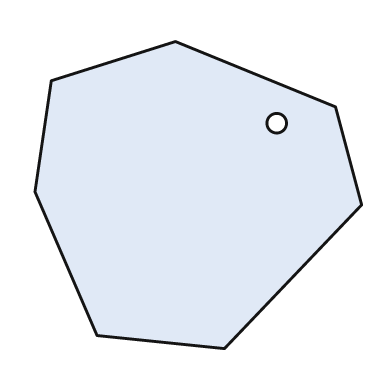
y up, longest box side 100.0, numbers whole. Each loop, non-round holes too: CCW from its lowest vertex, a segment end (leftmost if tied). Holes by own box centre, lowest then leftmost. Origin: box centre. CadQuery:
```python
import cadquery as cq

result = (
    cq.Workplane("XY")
    .moveTo(8.0, -47.0)
    .lineTo(50.0, -3.0)
    .lineTo(42.0, 27.0)
    .lineTo(-7.0, 47.0)
    .lineTo(-45.0, 35.0)
    .lineTo(-50.0, 1.0)
    .lineTo(-31.0, -43.0)
    .close()
    .moveTo(24.0, 22.0)
    .circle(3.0)
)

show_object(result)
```